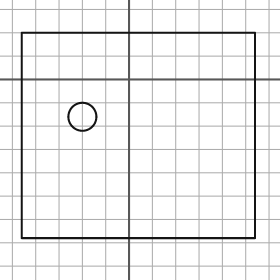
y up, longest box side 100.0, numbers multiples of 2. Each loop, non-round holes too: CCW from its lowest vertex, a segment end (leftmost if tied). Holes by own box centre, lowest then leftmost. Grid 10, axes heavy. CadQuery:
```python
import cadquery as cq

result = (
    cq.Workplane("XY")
    .moveTo(-46.0, -68.0)
    .lineTo(54.0, -68.0)
    .lineTo(54.0, 20.0)
    .lineTo(-46.0, 20.0)
    .close()
    .moveTo(-20.0, -16.0)
    .circle(6.0)
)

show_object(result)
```